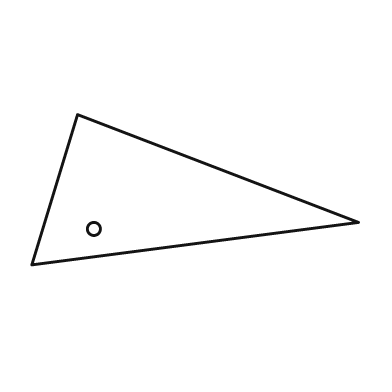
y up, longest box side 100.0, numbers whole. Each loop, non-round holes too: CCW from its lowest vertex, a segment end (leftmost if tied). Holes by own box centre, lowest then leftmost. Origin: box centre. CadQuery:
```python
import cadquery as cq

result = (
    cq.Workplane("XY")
    .moveTo(-50.0, -23.0)
    .lineTo(50.0, -10.0)
    .lineTo(-36.0, 23.0)
    .close()
    .moveTo(-31.0, -12.0)
    .circle(2.0)
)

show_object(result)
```